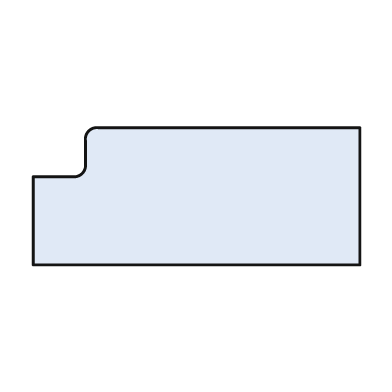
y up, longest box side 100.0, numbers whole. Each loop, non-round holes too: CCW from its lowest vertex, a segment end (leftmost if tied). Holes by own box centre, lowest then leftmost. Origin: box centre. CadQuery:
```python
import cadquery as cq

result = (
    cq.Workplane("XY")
    .moveTo(-50.0, -21.0)
    .lineTo(50.0, -21.0)
    .lineTo(50.0, 21.0)
    .lineTo(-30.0, 21.0)
    .threePointArc((-33.0, 20.0), (-34.0, 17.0))
    .lineTo(-34.0, 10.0)
    .threePointArc((-35.0, 7.0), (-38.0, 6.0))
    .lineTo(-50.0, 6.0)
    .close()
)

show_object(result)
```